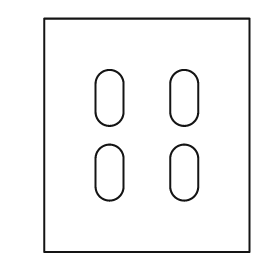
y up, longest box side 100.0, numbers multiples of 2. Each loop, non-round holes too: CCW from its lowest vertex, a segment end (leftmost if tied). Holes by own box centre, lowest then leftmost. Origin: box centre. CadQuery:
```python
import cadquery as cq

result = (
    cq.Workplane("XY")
    .moveTo(-44.0, -50.0)
    .lineTo(44.0, -50.0)
    .lineTo(44.0, 50.0)
    .lineTo(-44.0, 50.0)
    .close()
    .moveTo(-22.0, -22.0)
    .threePointArc((-16.0, -28.0), (-10.0, -22.0))
    .lineTo(-10.0, -10.0)
    .threePointArc((-16.0, -4.0), (-22.0, -10.0))
    .close()
    .moveTo(10.0, -22.0)
    .threePointArc((16.0, -28.0), (22.0, -22.0))
    .lineTo(22.0, -10.0)
    .threePointArc((16.0, -4.0), (10.0, -10.0))
    .close()
    .moveTo(-22.0, 10.0)
    .threePointArc((-16.0, 4.0), (-10.0, 10.0))
    .lineTo(-10.0, 22.0)
    .threePointArc((-16.0, 28.0), (-22.0, 22.0))
    .close()
    .moveTo(10.0, 10.0)
    .threePointArc((16.0, 4.0), (22.0, 10.0))
    .lineTo(22.0, 22.0)
    .threePointArc((16.0, 28.0), (10.0, 22.0))
    .close()
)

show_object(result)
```